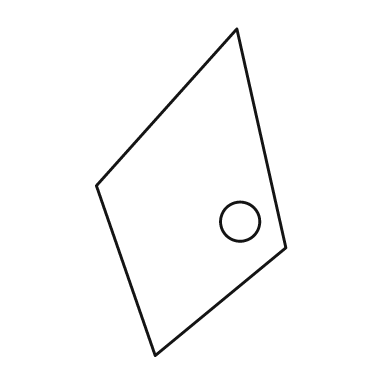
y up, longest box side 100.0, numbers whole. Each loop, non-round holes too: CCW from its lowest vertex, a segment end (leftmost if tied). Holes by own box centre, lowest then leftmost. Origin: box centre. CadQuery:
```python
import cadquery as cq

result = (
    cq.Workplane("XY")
    .moveTo(-11.0, -50.0)
    .lineTo(29.0, -17.0)
    .lineTo(14.0, 50.0)
    .lineTo(-29.0, 2.0)
    .close()
    .moveTo(15.0, -9.0)
    .circle(6.0)
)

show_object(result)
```